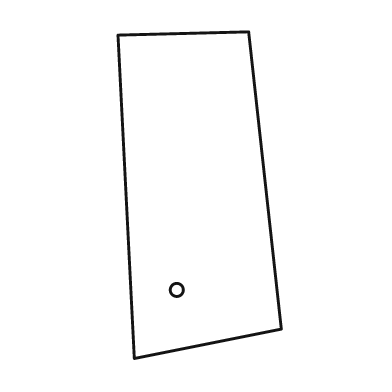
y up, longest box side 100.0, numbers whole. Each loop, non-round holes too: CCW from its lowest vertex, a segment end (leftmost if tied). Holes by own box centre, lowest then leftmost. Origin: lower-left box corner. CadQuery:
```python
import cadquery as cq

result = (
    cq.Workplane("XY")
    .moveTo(5.0, 0.0)
    .lineTo(50.0, 9.0)
    .lineTo(40.0, 100.0)
    .lineTo(0.0, 99.0)
    .close()
    .moveTo(18.0, 21.0)
    .circle(2.0)
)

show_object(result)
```